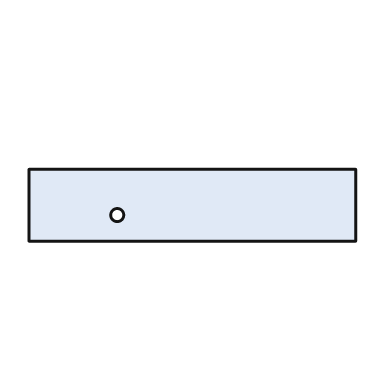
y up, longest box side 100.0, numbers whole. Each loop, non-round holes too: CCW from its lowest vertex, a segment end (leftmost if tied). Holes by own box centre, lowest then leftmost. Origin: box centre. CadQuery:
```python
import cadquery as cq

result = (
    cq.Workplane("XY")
    .moveTo(-50.0, -11.0)
    .lineTo(50.0, -11.0)
    .lineTo(50.0, 11.0)
    .lineTo(-50.0, 11.0)
    .close()
    .moveTo(-23.0, -3.0)
    .circle(2.0)
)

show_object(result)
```